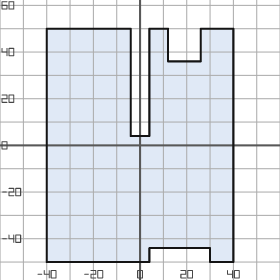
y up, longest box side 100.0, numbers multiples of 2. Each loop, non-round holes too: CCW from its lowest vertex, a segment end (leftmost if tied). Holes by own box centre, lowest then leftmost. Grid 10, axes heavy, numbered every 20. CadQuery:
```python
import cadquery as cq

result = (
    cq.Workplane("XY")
    .moveTo(-40.0, -50.0)
    .lineTo(4.0, -50.0)
    .lineTo(4.0, -44.0)
    .lineTo(30.0, -44.0)
    .lineTo(30.0, -50.0)
    .lineTo(40.0, -50.0)
    .lineTo(40.0, 50.0)
    .lineTo(26.0, 50.0)
    .lineTo(26.0, 36.0)
    .lineTo(12.0, 36.0)
    .lineTo(12.0, 50.0)
    .lineTo(4.0, 50.0)
    .lineTo(4.0, 4.0)
    .lineTo(-4.0, 4.0)
    .lineTo(-4.0, 50.0)
    .lineTo(-40.0, 50.0)
    .close()
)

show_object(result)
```